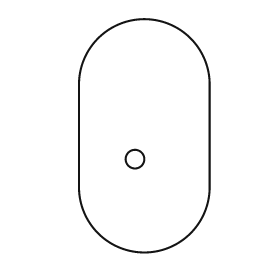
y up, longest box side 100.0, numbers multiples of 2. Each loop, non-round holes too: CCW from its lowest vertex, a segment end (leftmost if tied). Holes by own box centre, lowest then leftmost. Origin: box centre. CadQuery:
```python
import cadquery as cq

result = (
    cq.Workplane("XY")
    .moveTo(-28.0, -22.0)
    .threePointArc((0.0, -50.0), (28.0, -22.0))
    .lineTo(28.0, 22.0)
    .threePointArc((0.0, 50.0), (-28.0, 22.0))
    .close()
    .moveTo(-4.0, -10.0)
    .circle(4.0)
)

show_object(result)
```